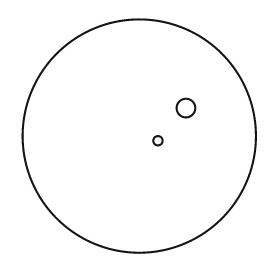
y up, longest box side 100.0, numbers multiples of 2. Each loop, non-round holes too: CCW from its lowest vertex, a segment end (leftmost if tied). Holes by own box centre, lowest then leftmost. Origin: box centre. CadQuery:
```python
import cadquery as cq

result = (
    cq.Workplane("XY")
    .moveTo(0.0, 0.0)
    .circle(50.0)
    .moveTo(8.0, -2.0)
    .circle(2.0)
    .moveTo(20.0, 12.0)
    .circle(4.0)
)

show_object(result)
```